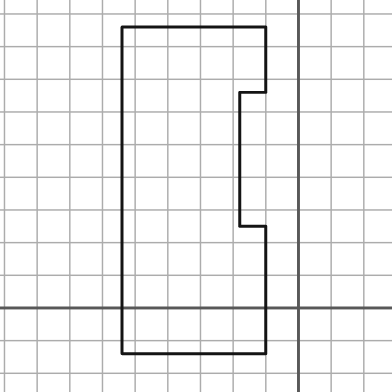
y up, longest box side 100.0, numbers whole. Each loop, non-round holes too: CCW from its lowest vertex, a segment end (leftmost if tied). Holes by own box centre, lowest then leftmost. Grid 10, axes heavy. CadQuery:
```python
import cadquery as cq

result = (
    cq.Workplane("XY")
    .moveTo(-54.0, -14.0)
    .lineTo(-10.0, -14.0)
    .lineTo(-10.0, 25.0)
    .lineTo(-18.0, 25.0)
    .lineTo(-18.0, 66.0)
    .lineTo(-10.0, 66.0)
    .lineTo(-10.0, 86.0)
    .lineTo(-54.0, 86.0)
    .close()
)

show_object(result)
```